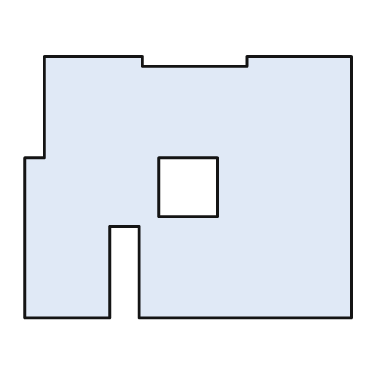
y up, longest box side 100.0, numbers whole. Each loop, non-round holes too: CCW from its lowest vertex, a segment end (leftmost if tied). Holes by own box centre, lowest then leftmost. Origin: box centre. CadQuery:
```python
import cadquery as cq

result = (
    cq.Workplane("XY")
    .moveTo(-50.0, -40.0)
    .lineTo(-24.0, -40.0)
    .lineTo(-24.0, -12.0)
    .lineTo(-15.0, -12.0)
    .lineTo(-15.0, -40.0)
    .lineTo(50.0, -40.0)
    .lineTo(50.0, 40.0)
    .lineTo(18.0, 40.0)
    .lineTo(18.0, 37.0)
    .lineTo(-14.0, 37.0)
    .lineTo(-14.0, 40.0)
    .lineTo(-44.0, 40.0)
    .lineTo(-44.0, 9.0)
    .lineTo(-50.0, 9.0)
    .close()
    .moveTo(-9.0, -9.0)
    .lineTo(9.0, -9.0)
    .lineTo(9.0, 9.0)
    .lineTo(-9.0, 9.0)
    .close()
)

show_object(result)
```